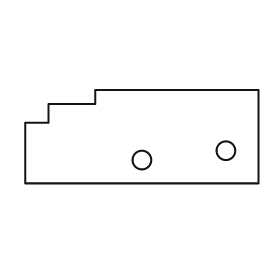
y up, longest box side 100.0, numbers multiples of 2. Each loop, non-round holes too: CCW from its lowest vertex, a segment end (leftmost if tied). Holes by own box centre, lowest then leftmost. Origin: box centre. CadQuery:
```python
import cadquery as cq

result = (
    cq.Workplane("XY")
    .moveTo(-50.0, -20.0)
    .lineTo(50.0, -20.0)
    .lineTo(50.0, 20.0)
    .lineTo(-20.0, 20.0)
    .lineTo(-20.0, 14.0)
    .lineTo(-40.0, 14.0)
    .lineTo(-40.0, 6.0)
    .lineTo(-50.0, 6.0)
    .close()
    .moveTo(0.0, -10.0)
    .circle(4.0)
    .moveTo(36.0, -6.0)
    .circle(4.0)
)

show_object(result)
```